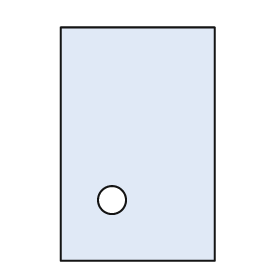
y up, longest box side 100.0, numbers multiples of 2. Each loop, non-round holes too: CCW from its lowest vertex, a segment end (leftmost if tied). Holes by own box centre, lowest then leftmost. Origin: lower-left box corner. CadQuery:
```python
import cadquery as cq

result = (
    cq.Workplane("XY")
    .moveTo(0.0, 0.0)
    .lineTo(66.0, 0.0)
    .lineTo(66.0, 100.0)
    .lineTo(0.0, 100.0)
    .close()
    .moveTo(22.0, 26.0)
    .circle(6.0)
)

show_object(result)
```